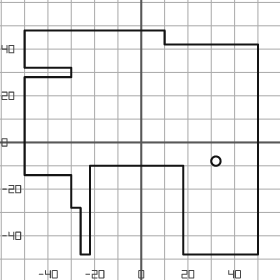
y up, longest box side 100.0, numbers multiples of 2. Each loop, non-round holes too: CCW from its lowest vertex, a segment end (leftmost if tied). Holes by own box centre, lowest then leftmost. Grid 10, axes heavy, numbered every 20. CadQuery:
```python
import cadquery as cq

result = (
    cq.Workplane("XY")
    .moveTo(-26.0, -48.0)
    .lineTo(-22.0, -48.0)
    .lineTo(-22.0, -10.0)
    .lineTo(18.0, -10.0)
    .lineTo(18.0, -48.0)
    .lineTo(50.0, -48.0)
    .lineTo(50.0, 42.0)
    .lineTo(10.0, 42.0)
    .lineTo(10.0, 48.0)
    .lineTo(-50.0, 48.0)
    .lineTo(-50.0, 32.0)
    .lineTo(-30.0, 32.0)
    .lineTo(-30.0, 28.0)
    .lineTo(-50.0, 28.0)
    .lineTo(-50.0, -14.0)
    .lineTo(-30.0, -14.0)
    .lineTo(-30.0, -28.0)
    .lineTo(-26.0, -28.0)
    .close()
    .moveTo(32.0, -8.0)
    .circle(2.0)
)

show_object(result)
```